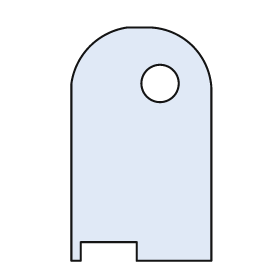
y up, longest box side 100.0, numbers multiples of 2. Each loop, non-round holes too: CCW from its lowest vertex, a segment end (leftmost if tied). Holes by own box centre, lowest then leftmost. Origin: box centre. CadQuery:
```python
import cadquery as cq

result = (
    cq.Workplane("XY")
    .moveTo(-30.0, -50.0)
    .lineTo(-26.0, -50.0)
    .lineTo(-26.0, -42.0)
    .lineTo(-2.0, -42.0)
    .lineTo(-2.0, -50.0)
    .lineTo(30.0, -50.0)
    .lineTo(30.0, 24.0)
    .threePointArc((22.0, 42.0), (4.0, 50.0))
    .lineTo(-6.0, 50.0)
    .threePointArc((-22.0, 42.0), (-30.0, 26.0))
    .close()
    .moveTo(8.0, 26.0)
    .circle(8.0)
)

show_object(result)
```